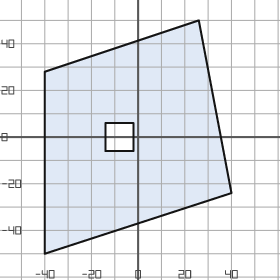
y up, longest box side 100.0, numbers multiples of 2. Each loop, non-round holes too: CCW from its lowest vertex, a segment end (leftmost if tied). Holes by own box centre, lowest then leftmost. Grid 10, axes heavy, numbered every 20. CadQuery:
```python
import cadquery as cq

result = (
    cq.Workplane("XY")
    .moveTo(-40.0, -50.0)
    .lineTo(40.0, -24.0)
    .lineTo(26.0, 50.0)
    .lineTo(-40.0, 28.0)
    .close()
    .moveTo(-14.0, -6.0)
    .lineTo(-2.0, -6.0)
    .lineTo(-2.0, 6.0)
    .lineTo(-14.0, 6.0)
    .close()
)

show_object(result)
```